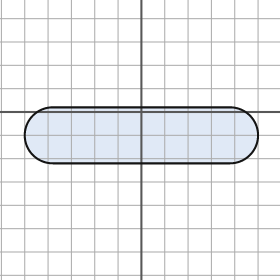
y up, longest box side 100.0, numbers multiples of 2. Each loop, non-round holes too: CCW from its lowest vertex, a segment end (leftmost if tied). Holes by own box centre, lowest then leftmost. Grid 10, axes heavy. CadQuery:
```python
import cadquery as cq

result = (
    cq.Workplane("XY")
    .moveTo(-38.0, -22.0)
    .lineTo(38.0, -22.0)
    .threePointArc((50.0, -10.0), (38.0, 2.0))
    .lineTo(-38.0, 2.0)
    .threePointArc((-50.0, -10.0), (-38.0, -22.0))
    .close()
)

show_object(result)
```